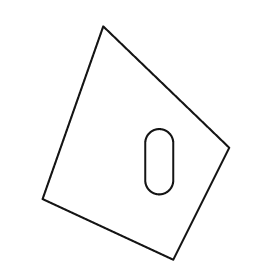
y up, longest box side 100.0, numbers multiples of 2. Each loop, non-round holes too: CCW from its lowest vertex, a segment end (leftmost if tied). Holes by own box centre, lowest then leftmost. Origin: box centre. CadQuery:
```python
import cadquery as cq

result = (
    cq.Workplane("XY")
    .moveTo(16.0, -50.0)
    .lineTo(40.0, -2.0)
    .lineTo(-14.0, 50.0)
    .lineTo(-40.0, -24.0)
    .close()
    .moveTo(4.0, -16.0)
    .threePointArc((10.0, -22.0), (16.0, -16.0))
    .lineTo(16.0, 0.0)
    .threePointArc((10.0, 6.0), (4.0, 0.0))
    .close()
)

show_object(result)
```